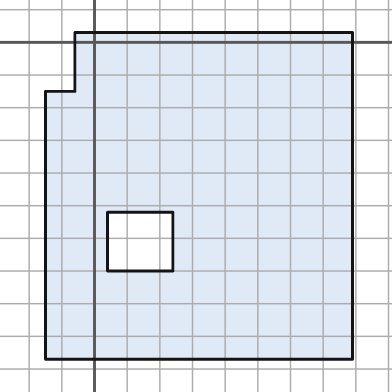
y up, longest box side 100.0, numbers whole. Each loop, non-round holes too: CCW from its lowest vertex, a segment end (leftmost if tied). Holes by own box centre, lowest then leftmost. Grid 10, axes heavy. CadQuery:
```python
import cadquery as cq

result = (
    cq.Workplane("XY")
    .moveTo(-15.0, -97.0)
    .lineTo(79.0, -97.0)
    .lineTo(79.0, 3.0)
    .lineTo(-6.0, 3.0)
    .lineTo(-6.0, -15.0)
    .lineTo(-15.0, -15.0)
    .close()
    .moveTo(4.0, -70.0)
    .lineTo(24.0, -70.0)
    .lineTo(24.0, -52.0)
    .lineTo(4.0, -52.0)
    .close()
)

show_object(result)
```